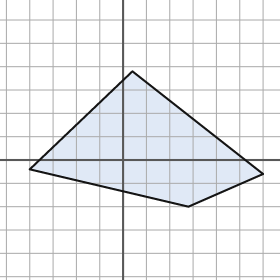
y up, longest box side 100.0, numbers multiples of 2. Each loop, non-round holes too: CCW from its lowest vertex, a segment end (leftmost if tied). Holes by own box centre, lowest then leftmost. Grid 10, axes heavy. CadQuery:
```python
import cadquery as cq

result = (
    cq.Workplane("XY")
    .moveTo(28.0, -20.0)
    .lineTo(60.0, -6.0)
    .lineTo(4.0, 38.0)
    .lineTo(-40.0, -4.0)
    .close()
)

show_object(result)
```